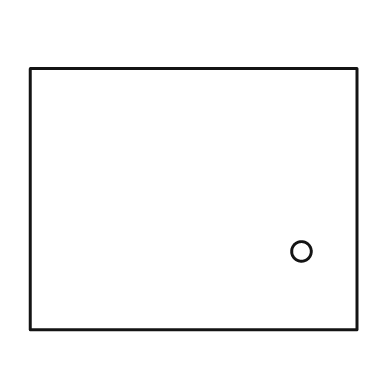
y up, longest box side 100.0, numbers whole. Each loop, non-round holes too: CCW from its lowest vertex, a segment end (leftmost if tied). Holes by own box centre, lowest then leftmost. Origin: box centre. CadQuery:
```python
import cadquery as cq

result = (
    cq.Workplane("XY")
    .moveTo(-50.0, -40.0)
    .lineTo(50.0, -40.0)
    .lineTo(50.0, 40.0)
    .lineTo(-50.0, 40.0)
    .close()
    .moveTo(33.0, -16.0)
    .circle(3.0)
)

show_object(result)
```